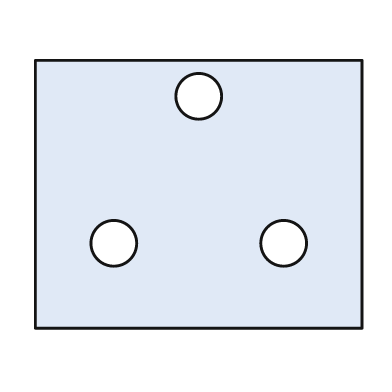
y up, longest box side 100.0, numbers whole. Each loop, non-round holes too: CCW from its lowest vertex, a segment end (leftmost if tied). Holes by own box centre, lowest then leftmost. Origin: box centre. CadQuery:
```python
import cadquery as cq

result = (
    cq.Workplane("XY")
    .moveTo(-50.0, -41.0)
    .lineTo(50.0, -41.0)
    .lineTo(50.0, 41.0)
    .lineTo(-50.0, 41.0)
    .close()
    .moveTo(-26.0, -15.0)
    .circle(7.0)
    .moveTo(26.0, -15.0)
    .circle(7.0)
    .moveTo(0.0, 30.0)
    .circle(7.0)
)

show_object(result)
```